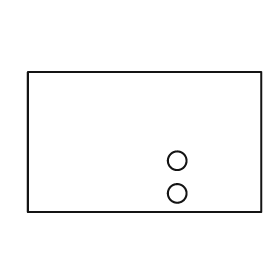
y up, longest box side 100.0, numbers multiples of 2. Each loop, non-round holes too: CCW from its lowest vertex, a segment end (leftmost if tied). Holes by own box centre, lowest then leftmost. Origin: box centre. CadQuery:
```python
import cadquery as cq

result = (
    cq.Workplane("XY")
    .moveTo(-50.0, -30.0)
    .lineTo(50.0, -30.0)
    .lineTo(50.0, 30.0)
    .lineTo(-50.0, 30.0)
    .close()
    .moveTo(14.0, -22.0)
    .circle(4.0)
    .moveTo(14.0, -8.0)
    .circle(4.0)
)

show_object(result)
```